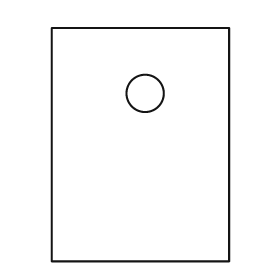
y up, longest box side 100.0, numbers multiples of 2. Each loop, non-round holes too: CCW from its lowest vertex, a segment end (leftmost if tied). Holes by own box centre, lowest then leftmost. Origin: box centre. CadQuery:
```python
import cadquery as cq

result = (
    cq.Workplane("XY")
    .moveTo(-38.0, -50.0)
    .lineTo(38.0, -50.0)
    .lineTo(38.0, 50.0)
    .lineTo(-38.0, 50.0)
    .close()
    .moveTo(2.0, 22.0)
    .circle(8.0)
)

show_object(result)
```